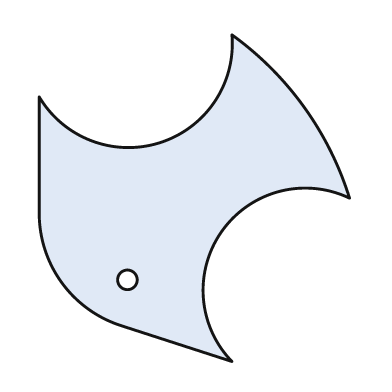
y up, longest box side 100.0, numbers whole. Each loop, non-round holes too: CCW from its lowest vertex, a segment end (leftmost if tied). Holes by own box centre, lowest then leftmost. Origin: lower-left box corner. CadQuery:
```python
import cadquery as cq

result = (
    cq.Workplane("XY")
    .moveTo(59.0, 0.0)
    .threePointArc((56.0, 40.0), (95.0, 50.0))
    .threePointArc((81.0, 78.0), (59.0, 100.0))
    .threePointArc((37.0, 67.0), (0.0, 81.0))
    .lineTo(0.0, 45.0)
    .threePointArc((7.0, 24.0), (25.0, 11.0))
    .close()
    .moveTo(27.0, 25.0)
    .circle(3.0)
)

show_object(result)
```